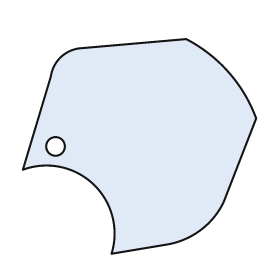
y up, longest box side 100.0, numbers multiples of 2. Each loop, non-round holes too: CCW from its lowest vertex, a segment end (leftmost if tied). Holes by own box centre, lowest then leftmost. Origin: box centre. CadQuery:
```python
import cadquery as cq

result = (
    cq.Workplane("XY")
    .moveTo(-12.0, -46.0)
    .lineTo(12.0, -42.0)
    .threePointArc((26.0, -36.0), (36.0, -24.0))
    .lineTo(50.0, 12.0)
    .threePointArc((38.0, 32.0), (20.0, 46.0))
    .lineTo(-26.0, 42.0)
    .threePointArc((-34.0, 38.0), (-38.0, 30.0))
    .lineTo(-50.0, -10.0)
    .threePointArc((-20.0, -16.0), (-12.0, -46.0))
    .close()
    .moveTo(-36.0, 0.0)
    .circle(4.0)
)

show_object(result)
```